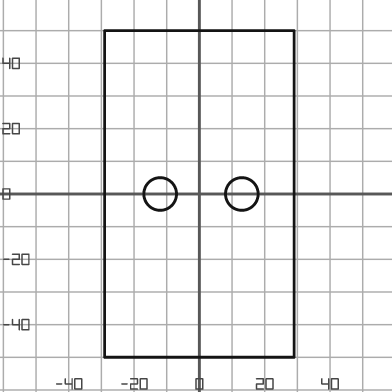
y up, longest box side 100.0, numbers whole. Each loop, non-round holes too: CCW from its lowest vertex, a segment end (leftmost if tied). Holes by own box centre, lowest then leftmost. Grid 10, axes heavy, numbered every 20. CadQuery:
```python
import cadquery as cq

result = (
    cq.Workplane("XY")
    .moveTo(-29.0, -50.0)
    .lineTo(29.0, -50.0)
    .lineTo(29.0, 50.0)
    .lineTo(-29.0, 50.0)
    .close()
    .moveTo(-12.0, 0.0)
    .circle(5.0)
    .moveTo(13.0, 0.0)
    .circle(5.0)
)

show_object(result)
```